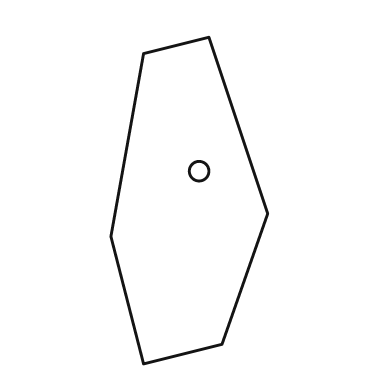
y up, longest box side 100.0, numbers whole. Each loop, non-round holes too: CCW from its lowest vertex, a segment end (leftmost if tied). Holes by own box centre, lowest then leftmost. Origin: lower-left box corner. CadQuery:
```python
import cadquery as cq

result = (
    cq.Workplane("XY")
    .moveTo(10.0, 0.0)
    .lineTo(34.0, 6.0)
    .lineTo(48.0, 46.0)
    .lineTo(30.0, 100.0)
    .lineTo(10.0, 95.0)
    .lineTo(0.0, 39.0)
    .close()
    .moveTo(27.0, 59.0)
    .circle(3.0)
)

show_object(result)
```